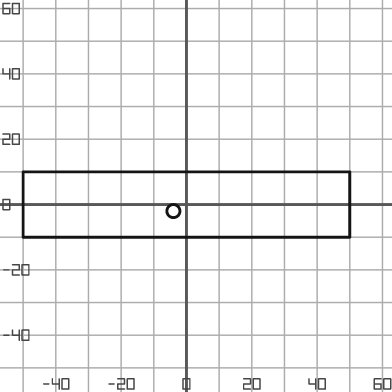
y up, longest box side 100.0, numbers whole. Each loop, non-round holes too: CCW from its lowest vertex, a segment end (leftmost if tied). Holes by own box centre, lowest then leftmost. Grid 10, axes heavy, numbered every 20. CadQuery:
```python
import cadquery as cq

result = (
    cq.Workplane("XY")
    .moveTo(-50.0, -10.0)
    .lineTo(50.0, -10.0)
    .lineTo(50.0, 10.0)
    .lineTo(-50.0, 10.0)
    .close()
    .moveTo(-4.0, -2.0)
    .circle(2.0)
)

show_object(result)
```